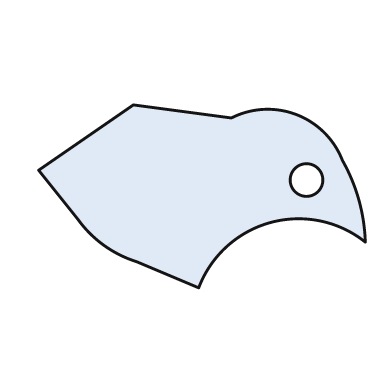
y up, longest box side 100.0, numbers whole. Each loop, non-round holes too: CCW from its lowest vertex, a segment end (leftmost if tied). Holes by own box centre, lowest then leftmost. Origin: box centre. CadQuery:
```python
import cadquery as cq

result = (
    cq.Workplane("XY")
    .moveTo(-1.0, -28.0)
    .threePointArc((21.0, -8.0), (50.0, -14.0))
    .threePointArc((48.0, -1.0), (43.0, 11.0))
    .threePointArc((29.0, 25.0), (9.0, 24.0))
    .lineTo(-21.0, 28.0)
    .lineTo(-50.0, 8.0)
    .lineTo(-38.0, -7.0)
    .threePointArc((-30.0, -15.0), (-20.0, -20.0))
    .close()
    .moveTo(32.0, 5.0)
    .circle(5.0)
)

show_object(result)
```